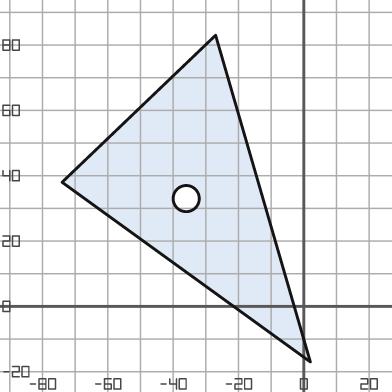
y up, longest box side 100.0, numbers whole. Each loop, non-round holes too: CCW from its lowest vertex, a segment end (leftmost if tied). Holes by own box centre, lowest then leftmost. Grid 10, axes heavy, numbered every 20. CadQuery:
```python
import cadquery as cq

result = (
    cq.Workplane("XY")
    .moveTo(2.0, -17.0)
    .lineTo(-27.0, 83.0)
    .lineTo(-74.0, 38.0)
    .close()
    .moveTo(-36.0, 33.0)
    .circle(4.0)
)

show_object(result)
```